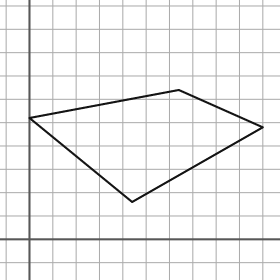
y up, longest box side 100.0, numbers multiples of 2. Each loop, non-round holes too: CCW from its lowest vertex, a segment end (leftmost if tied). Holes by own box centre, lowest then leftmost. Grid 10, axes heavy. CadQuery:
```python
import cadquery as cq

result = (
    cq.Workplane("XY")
    .moveTo(44.0, 16.0)
    .lineTo(100.0, 48.0)
    .lineTo(64.0, 64.0)
    .lineTo(0.0, 52.0)
    .close()
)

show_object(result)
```